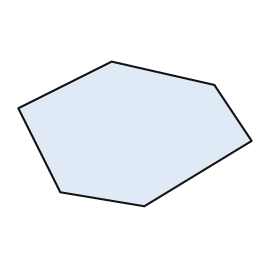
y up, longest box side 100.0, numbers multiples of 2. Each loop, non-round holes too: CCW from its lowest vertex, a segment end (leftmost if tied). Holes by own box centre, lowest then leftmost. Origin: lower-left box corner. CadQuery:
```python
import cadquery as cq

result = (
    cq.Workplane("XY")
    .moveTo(54.0, 0.0)
    .lineTo(100.0, 28.0)
    .lineTo(84.0, 52.0)
    .lineTo(40.0, 62.0)
    .lineTo(0.0, 42.0)
    .lineTo(18.0, 6.0)
    .close()
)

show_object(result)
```